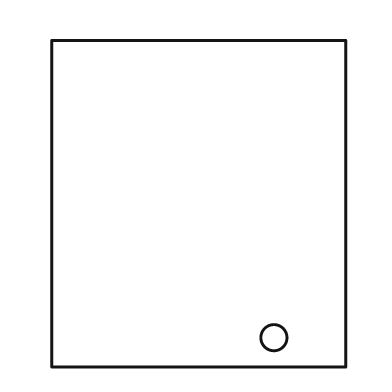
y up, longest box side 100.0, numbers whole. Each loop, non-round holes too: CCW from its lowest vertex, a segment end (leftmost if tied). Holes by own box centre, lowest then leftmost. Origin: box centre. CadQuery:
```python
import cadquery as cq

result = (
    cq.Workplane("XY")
    .moveTo(-45.0, -50.0)
    .lineTo(45.0, -50.0)
    .lineTo(45.0, 50.0)
    .lineTo(-45.0, 50.0)
    .close()
    .moveTo(23.0, -41.0)
    .circle(4.0)
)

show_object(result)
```